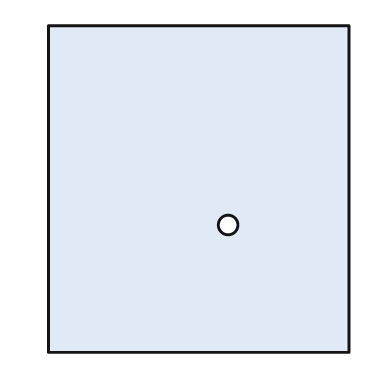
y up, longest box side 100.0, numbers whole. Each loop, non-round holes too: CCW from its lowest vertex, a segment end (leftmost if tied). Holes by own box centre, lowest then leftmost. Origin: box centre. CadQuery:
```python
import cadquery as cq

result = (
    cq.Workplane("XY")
    .moveTo(-46.0, -50.0)
    .lineTo(46.0, -50.0)
    .lineTo(46.0, 50.0)
    .lineTo(-46.0, 50.0)
    .close()
    .moveTo(9.0, -11.0)
    .circle(3.0)
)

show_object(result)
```